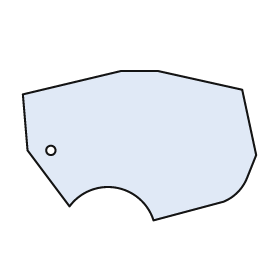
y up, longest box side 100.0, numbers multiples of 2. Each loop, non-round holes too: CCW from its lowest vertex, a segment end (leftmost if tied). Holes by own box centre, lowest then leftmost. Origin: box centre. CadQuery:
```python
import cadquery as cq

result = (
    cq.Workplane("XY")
    .moveTo(6.0, -32.0)
    .lineTo(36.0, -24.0)
    .threePointArc((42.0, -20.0), (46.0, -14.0))
    .lineTo(50.0, -4.0)
    .lineTo(44.0, 24.0)
    .lineTo(8.0, 32.0)
    .lineTo(-8.0, 32.0)
    .lineTo(-50.0, 22.0)
    .lineTo(-48.0, -2.0)
    .lineTo(-30.0, -26.0)
    .threePointArc((-10.0, -18.0), (6.0, -32.0))
    .close()
    .moveTo(-38.0, -2.0)
    .circle(2.0)
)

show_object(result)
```